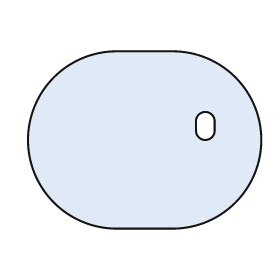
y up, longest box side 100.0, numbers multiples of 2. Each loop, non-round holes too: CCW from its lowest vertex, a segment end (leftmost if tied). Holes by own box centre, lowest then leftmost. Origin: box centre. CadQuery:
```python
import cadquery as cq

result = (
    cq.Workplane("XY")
    .moveTo(-12.0, -38.0)
    .lineTo(12.0, -38.0)
    .threePointArc((50.0, 0.0), (12.0, 38.0))
    .lineTo(-12.0, 38.0)
    .threePointArc((-50.0, 0.0), (-12.0, -38.0))
    .close()
    .moveTo(22.0, 4.0)
    .threePointArc((26.0, 0.0), (30.0, 4.0))
    .lineTo(30.0, 8.0)
    .threePointArc((26.0, 12.0), (22.0, 8.0))
    .close()
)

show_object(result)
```